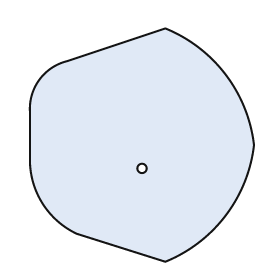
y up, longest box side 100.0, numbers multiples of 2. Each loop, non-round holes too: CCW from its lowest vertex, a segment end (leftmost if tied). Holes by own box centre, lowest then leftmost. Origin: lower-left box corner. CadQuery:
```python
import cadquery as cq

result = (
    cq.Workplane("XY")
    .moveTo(58.0, 0.0)
    .threePointArc((84.0, 20.0), (96.0, 50.0))
    .threePointArc((84.0, 80.0), (58.0, 100.0))
    .lineTo(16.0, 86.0)
    .threePointArc((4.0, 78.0), (0.0, 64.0))
    .lineTo(0.0, 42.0)
    .threePointArc((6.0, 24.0), (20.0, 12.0))
    .close()
    .moveTo(48.0, 40.0)
    .circle(2.0)
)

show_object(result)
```